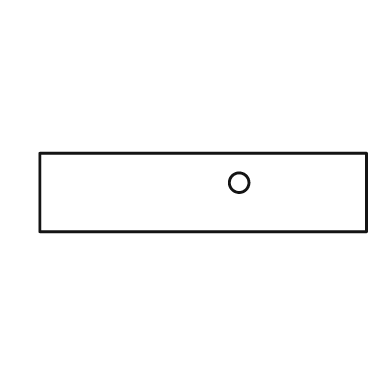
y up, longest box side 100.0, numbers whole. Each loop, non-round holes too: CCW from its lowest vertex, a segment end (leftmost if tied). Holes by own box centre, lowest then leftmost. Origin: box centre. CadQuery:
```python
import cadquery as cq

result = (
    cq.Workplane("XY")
    .moveTo(-50.0, -12.0)
    .lineTo(50.0, -12.0)
    .lineTo(50.0, 12.0)
    .lineTo(-50.0, 12.0)
    .close()
    .moveTo(11.0, 3.0)
    .circle(3.0)
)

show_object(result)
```